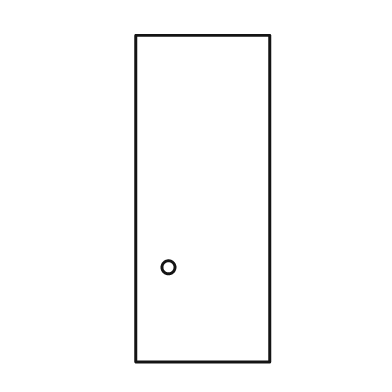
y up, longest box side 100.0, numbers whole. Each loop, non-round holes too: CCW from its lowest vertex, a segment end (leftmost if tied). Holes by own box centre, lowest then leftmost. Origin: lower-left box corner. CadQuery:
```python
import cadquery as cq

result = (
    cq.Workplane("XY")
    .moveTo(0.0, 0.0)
    .lineTo(41.0, 0.0)
    .lineTo(41.0, 100.0)
    .lineTo(0.0, 100.0)
    .close()
    .moveTo(10.0, 29.0)
    .circle(2.0)
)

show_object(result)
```